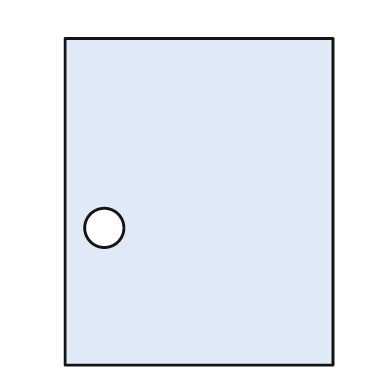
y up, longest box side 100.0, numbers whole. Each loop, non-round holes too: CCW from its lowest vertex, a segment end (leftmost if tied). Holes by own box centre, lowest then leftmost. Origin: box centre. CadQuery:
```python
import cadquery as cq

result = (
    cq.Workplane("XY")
    .moveTo(-41.0, -50.0)
    .lineTo(41.0, -50.0)
    .lineTo(41.0, 50.0)
    .lineTo(-41.0, 50.0)
    .close()
    .moveTo(-29.0, -8.0)
    .circle(6.0)
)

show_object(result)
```